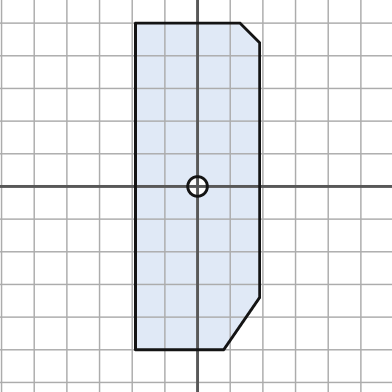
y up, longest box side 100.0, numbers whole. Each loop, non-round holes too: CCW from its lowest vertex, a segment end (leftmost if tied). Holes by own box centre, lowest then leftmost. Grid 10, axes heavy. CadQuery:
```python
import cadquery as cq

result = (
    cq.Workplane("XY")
    .moveTo(-19.0, -50.0)
    .lineTo(8.0, -50.0)
    .lineTo(19.0, -34.0)
    .lineTo(19.0, 44.0)
    .lineTo(13.0, 50.0)
    .lineTo(-19.0, 50.0)
    .close()
    .moveTo(0.0, 0.0)
    .circle(3.0)
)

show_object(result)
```